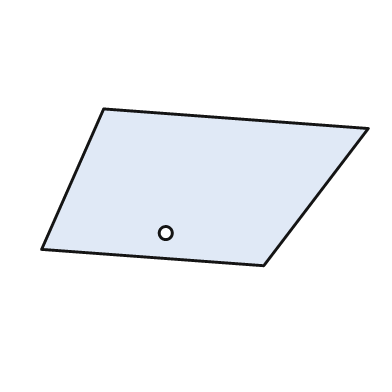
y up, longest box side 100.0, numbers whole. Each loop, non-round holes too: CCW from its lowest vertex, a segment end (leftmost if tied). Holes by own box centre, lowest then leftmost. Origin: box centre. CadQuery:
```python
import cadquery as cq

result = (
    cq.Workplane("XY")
    .moveTo(18.0, -24.0)
    .lineTo(50.0, 18.0)
    .lineTo(-31.0, 24.0)
    .lineTo(-50.0, -19.0)
    .close()
    .moveTo(-12.0, -14.0)
    .circle(2.0)
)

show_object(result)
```